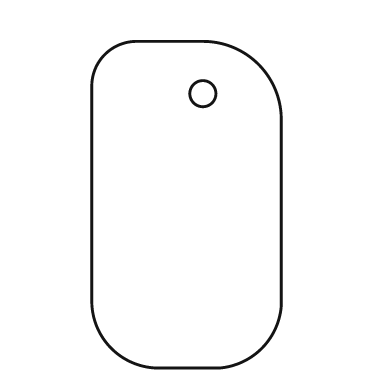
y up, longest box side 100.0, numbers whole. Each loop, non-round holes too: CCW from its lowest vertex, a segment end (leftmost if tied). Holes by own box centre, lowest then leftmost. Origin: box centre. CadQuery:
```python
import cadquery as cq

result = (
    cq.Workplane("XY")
    .moveTo(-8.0, -50.0)
    .lineTo(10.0, -50.0)
    .threePointArc((23.0, -44.0), (29.0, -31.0))
    .lineTo(29.0, 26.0)
    .threePointArc((22.0, 43.0), (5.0, 50.0))
    .lineTo(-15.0, 50.0)
    .threePointArc((-25.0, 46.0), (-29.0, 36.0))
    .lineTo(-29.0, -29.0)
    .threePointArc((-23.0, -44.0), (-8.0, -50.0))
    .close()
    .moveTo(5.0, 34.0)
    .circle(4.0)
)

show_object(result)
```